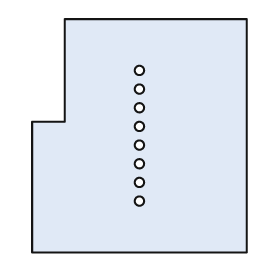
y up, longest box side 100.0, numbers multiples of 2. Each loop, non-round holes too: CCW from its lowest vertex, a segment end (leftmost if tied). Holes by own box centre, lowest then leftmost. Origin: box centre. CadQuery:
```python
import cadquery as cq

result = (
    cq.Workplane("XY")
    .moveTo(-46.0, -50.0)
    .lineTo(46.0, -50.0)
    .lineTo(46.0, 50.0)
    .lineTo(-32.0, 50.0)
    .lineTo(-32.0, 6.0)
    .lineTo(-46.0, 6.0)
    .close()
    .moveTo(0.0, -28.0)
    .circle(2.0)
    .moveTo(0.0, -20.0)
    .circle(2.0)
    .moveTo(0.0, -12.0)
    .circle(2.0)
    .moveTo(0.0, -4.0)
    .circle(2.0)
    .moveTo(0.0, 4.0)
    .circle(2.0)
    .moveTo(0.0, 12.0)
    .circle(2.0)
    .moveTo(0.0, 20.0)
    .circle(2.0)
    .moveTo(0.0, 28.0)
    .circle(2.0)
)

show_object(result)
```